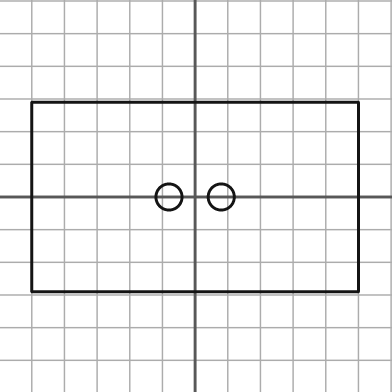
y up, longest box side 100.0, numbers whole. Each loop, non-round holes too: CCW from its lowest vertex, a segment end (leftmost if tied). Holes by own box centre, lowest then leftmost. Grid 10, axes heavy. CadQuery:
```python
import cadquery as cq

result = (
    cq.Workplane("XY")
    .moveTo(-50.0, -29.0)
    .lineTo(50.0, -29.0)
    .lineTo(50.0, 29.0)
    .lineTo(-50.0, 29.0)
    .close()
    .moveTo(-8.0, 0.0)
    .circle(4.0)
    .moveTo(8.0, 0.0)
    .circle(4.0)
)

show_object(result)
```